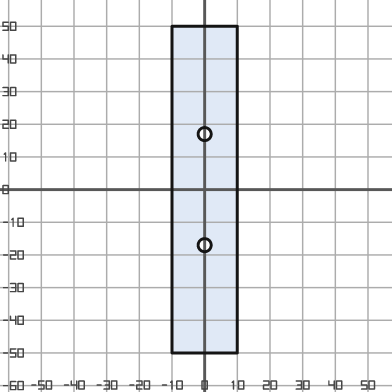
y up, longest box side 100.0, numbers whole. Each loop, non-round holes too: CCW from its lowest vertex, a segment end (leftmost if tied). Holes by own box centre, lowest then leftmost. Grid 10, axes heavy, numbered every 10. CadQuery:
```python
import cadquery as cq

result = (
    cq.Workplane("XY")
    .moveTo(-10.0, -50.0)
    .lineTo(10.0, -50.0)
    .lineTo(10.0, 50.0)
    .lineTo(-10.0, 50.0)
    .close()
    .moveTo(0.0, -17.0)
    .circle(2.0)
    .moveTo(0.0, 17.0)
    .circle(2.0)
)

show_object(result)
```